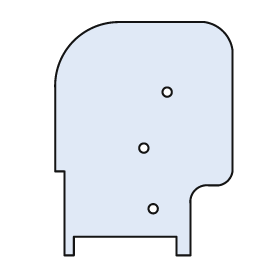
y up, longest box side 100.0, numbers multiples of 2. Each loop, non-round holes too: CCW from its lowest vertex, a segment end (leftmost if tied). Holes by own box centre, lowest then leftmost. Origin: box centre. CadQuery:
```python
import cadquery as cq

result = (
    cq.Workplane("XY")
    .moveTo(-34.0, -50.0)
    .lineTo(-30.0, -50.0)
    .lineTo(-30.0, -42.0)
    .lineTo(14.0, -42.0)
    .lineTo(14.0, -50.0)
    .lineTo(20.0, -50.0)
    .lineTo(20.0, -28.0)
    .threePointArc((22.0, -22.0), (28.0, -20.0))
    .lineTo(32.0, -20.0)
    .threePointArc((36.0, -18.0), (38.0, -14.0))
    .lineTo(38.0, 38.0)
    .threePointArc((34.0, 46.0), (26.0, 50.0))
    .lineTo(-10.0, 50.0)
    .threePointArc((-30.0, 42.0), (-38.0, 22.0))
    .lineTo(-38.0, -14.0)
    .lineTo(-34.0, -14.0)
    .close()
    .moveTo(4.0, -30.0)
    .circle(2.0)
    .moveTo(0.0, -4.0)
    .circle(2.0)
    .moveTo(10.0, 20.0)
    .circle(2.0)
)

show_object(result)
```